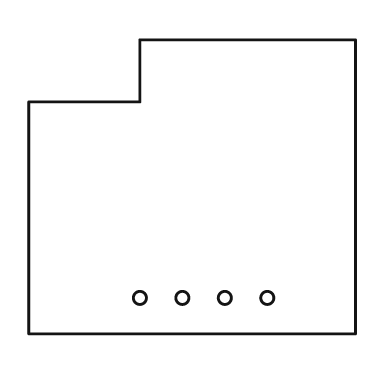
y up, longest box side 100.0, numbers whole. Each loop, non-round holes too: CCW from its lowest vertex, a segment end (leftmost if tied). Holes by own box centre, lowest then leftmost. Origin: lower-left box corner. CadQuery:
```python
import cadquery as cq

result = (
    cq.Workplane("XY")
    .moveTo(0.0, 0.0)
    .lineTo(100.0, 0.0)
    .lineTo(100.0, 90.0)
    .lineTo(34.0, 90.0)
    .lineTo(34.0, 71.0)
    .lineTo(0.0, 71.0)
    .close()
    .moveTo(34.0, 11.0)
    .circle(2.0)
    .moveTo(47.0, 11.0)
    .circle(2.0)
    .moveTo(60.0, 11.0)
    .circle(2.0)
    .moveTo(73.0, 11.0)
    .circle(2.0)
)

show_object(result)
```